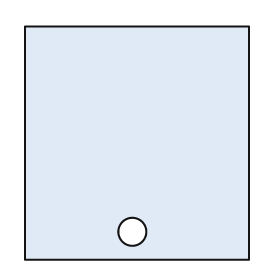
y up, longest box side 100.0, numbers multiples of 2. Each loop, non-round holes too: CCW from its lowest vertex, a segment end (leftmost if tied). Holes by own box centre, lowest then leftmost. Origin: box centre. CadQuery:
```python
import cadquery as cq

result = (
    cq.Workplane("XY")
    .moveTo(-48.0, -50.0)
    .lineTo(48.0, -50.0)
    .lineTo(48.0, 50.0)
    .lineTo(-48.0, 50.0)
    .close()
    .moveTo(-2.0, -38.0)
    .circle(6.0)
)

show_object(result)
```